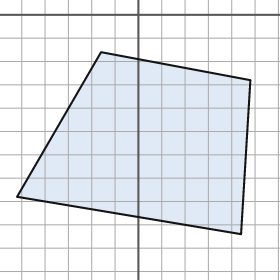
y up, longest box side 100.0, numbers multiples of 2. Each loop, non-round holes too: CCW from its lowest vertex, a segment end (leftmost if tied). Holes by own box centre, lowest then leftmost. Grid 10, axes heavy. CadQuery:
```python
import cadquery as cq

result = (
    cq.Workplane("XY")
    .moveTo(44.0, -94.0)
    .lineTo(48.0, -28.0)
    .lineTo(-16.0, -16.0)
    .lineTo(-52.0, -78.0)
    .close()
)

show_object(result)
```